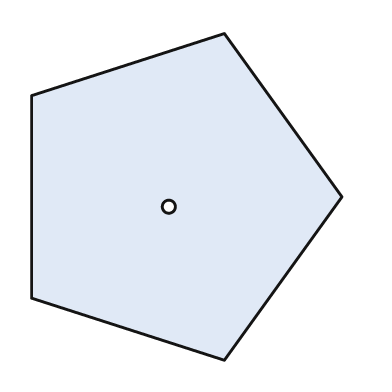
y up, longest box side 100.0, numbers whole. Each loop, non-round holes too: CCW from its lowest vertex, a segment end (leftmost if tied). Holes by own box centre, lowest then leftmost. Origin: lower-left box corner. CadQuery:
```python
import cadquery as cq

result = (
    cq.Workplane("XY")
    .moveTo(59.0, 0.0)
    .lineTo(95.0, 50.0)
    .lineTo(59.0, 100.0)
    .lineTo(0.0, 81.0)
    .lineTo(0.0, 19.0)
    .close()
    .moveTo(42.0, 47.0)
    .circle(2.0)
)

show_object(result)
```